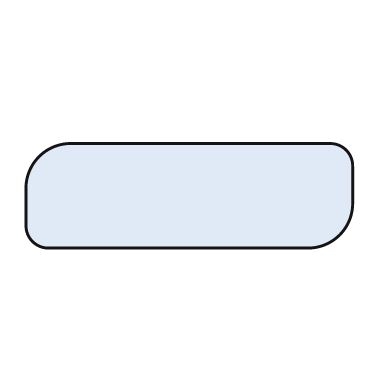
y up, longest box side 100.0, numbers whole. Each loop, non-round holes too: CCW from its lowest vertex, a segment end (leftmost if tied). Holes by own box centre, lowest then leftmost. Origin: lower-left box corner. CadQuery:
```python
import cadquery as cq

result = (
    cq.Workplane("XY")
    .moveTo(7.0, 0.0)
    .lineTo(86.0, 0.0)
    .threePointArc((96.0, 4.0), (100.0, 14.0))
    .lineTo(100.0, 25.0)
    .threePointArc((98.0, 30.0), (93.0, 32.0))
    .lineTo(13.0, 32.0)
    .threePointArc((4.0, 28.0), (0.0, 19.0))
    .lineTo(0.0, 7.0)
    .threePointArc((2.0, 2.0), (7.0, 0.0))
    .close()
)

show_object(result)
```